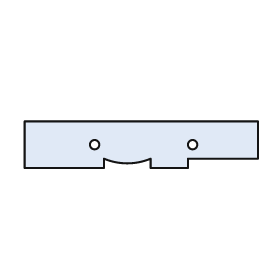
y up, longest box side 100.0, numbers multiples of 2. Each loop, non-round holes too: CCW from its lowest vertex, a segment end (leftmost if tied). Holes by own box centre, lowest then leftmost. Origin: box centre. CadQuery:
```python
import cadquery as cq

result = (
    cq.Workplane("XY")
    .moveTo(-50.0, -10.0)
    .lineTo(-16.0, -10.0)
    .lineTo(-16.0, -6.0)
    .threePointArc((-6.0, -8.0), (4.0, -6.0))
    .lineTo(4.0, -10.0)
    .lineTo(20.0, -10.0)
    .lineTo(20.0, -6.0)
    .lineTo(50.0, -6.0)
    .lineTo(50.0, 10.0)
    .lineTo(-50.0, 10.0)
    .close()
    .moveTo(-20.0, 0.0)
    .circle(2.0)
    .moveTo(22.0, 0.0)
    .circle(2.0)
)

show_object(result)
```